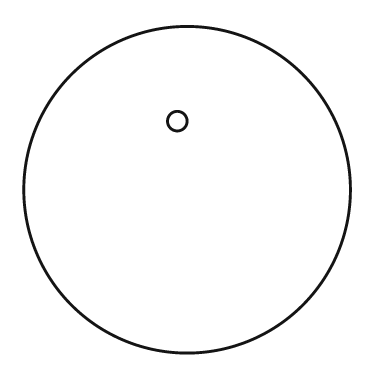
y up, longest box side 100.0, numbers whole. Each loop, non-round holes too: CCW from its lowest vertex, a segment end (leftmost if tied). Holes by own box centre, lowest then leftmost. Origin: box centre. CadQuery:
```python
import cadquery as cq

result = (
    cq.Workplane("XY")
    .moveTo(0.0, 0.0)
    .circle(50.0)
    .moveTo(-3.0, 21.0)
    .circle(3.0)
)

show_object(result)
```